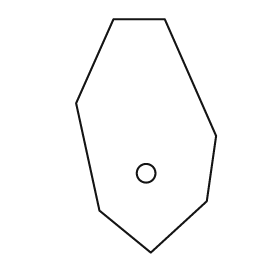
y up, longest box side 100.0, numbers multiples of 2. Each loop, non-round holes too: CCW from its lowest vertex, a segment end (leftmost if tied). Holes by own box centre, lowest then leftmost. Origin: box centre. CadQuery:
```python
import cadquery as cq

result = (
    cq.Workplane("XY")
    .moveTo(2.0, -50.0)
    .lineTo(26.0, -28.0)
    .lineTo(30.0, 0.0)
    .lineTo(8.0, 50.0)
    .lineTo(-14.0, 50.0)
    .lineTo(-30.0, 14.0)
    .lineTo(-20.0, -32.0)
    .close()
    .moveTo(0.0, -16.0)
    .circle(4.0)
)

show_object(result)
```